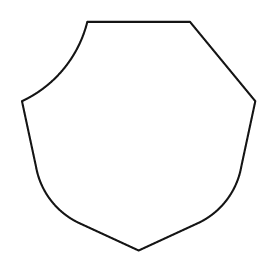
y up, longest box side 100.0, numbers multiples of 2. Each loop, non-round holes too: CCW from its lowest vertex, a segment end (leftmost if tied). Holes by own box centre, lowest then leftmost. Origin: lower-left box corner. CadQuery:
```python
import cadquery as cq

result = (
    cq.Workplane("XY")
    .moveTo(50.0, 0.0)
    .lineTo(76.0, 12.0)
    .threePointArc((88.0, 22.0), (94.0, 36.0))
    .lineTo(100.0, 64.0)
    .lineTo(72.0, 98.0)
    .lineTo(28.0, 98.0)
    .threePointArc((18.0, 78.0), (0.0, 64.0))
    .lineTo(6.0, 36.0)
    .threePointArc((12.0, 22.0), (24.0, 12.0))
    .close()
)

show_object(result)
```